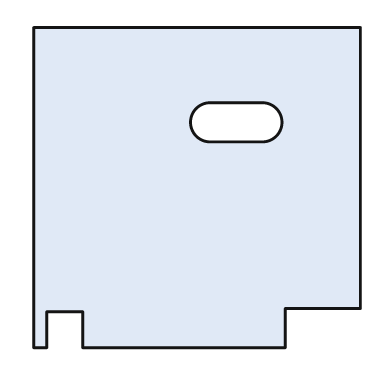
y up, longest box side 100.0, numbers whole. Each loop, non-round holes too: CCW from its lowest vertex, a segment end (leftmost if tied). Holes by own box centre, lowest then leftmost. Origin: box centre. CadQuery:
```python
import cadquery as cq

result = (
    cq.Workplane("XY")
    .moveTo(-50.0, -49.0)
    .lineTo(-46.0, -49.0)
    .lineTo(-46.0, -38.0)
    .lineTo(-35.0, -38.0)
    .lineTo(-35.0, -49.0)
    .lineTo(27.0, -49.0)
    .lineTo(27.0, -37.0)
    .lineTo(50.0, -37.0)
    .lineTo(50.0, 49.0)
    .lineTo(-50.0, 49.0)
    .close()
    .moveTo(4.0, 14.0)
    .lineTo(20.0, 14.0)
    .threePointArc((26.0, 20.0), (20.0, 26.0))
    .lineTo(4.0, 26.0)
    .threePointArc((-2.0, 20.0), (4.0, 14.0))
    .close()
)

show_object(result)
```